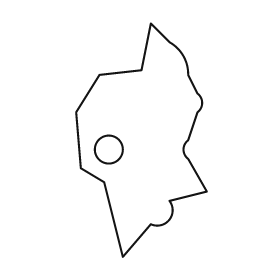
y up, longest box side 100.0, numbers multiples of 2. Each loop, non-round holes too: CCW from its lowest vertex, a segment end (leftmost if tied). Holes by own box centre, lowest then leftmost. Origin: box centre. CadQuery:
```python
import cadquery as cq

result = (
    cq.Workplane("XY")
    .moveTo(-8.0, -50.0)
    .lineTo(4.0, -36.0)
    .threePointArc((12.0, -34.0), (12.0, -26.0))
    .lineTo(28.0, -22.0)
    .lineTo(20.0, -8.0)
    .threePointArc((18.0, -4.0), (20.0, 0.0))
    .lineTo(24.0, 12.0)
    .threePointArc((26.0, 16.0), (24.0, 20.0))
    .lineTo(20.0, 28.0)
    .threePointArc((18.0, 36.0), (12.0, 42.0))
    .lineTo(4.0, 50.0)
    .lineTo(0.0, 30.0)
    .lineTo(-18.0, 28.0)
    .lineTo(-28.0, 12.0)
    .lineTo(-26.0, -12.0)
    .lineTo(-16.0, -18.0)
    .close()
    .moveTo(-14.0, -4.0)
    .circle(6.0)
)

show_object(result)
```